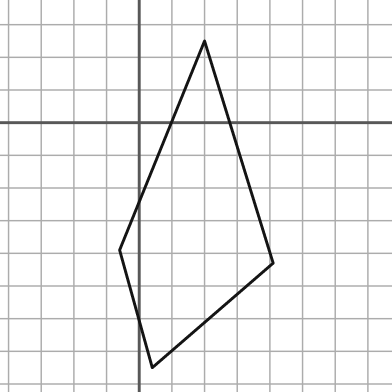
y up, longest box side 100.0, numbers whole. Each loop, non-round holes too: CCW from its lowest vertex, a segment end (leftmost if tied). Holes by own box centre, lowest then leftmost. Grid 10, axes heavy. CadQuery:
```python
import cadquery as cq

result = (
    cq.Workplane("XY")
    .moveTo(4.0, -75.0)
    .lineTo(41.0, -43.0)
    .lineTo(20.0, 25.0)
    .lineTo(-6.0, -39.0)
    .close()
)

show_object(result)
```